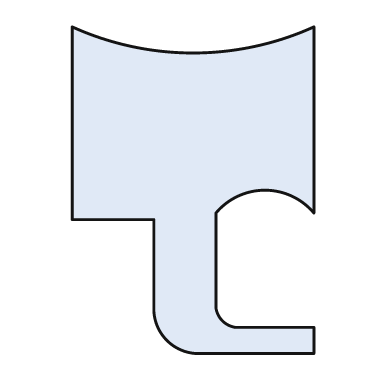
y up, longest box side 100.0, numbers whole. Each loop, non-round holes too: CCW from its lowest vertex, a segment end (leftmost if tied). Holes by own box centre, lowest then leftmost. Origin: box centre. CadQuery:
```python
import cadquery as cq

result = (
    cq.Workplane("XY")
    .moveTo(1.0, -50.0)
    .lineTo(37.0, -50.0)
    .lineTo(37.0, -42.0)
    .lineTo(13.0, -42.0)
    .threePointArc((9.0, -40.0), (7.0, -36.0))
    .lineTo(7.0, -7.0)
    .threePointArc((22.0, 0.0), (37.0, -7.0))
    .lineTo(37.0, 50.0)
    .threePointArc((0.0, 42.0), (-37.0, 50.0))
    .lineTo(-37.0, -9.0)
    .lineTo(-12.0, -9.0)
    .lineTo(-12.0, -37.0)
    .threePointArc((-8.0, -46.0), (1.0, -50.0))
    .close()
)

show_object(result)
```